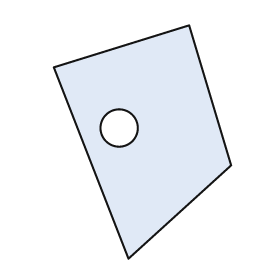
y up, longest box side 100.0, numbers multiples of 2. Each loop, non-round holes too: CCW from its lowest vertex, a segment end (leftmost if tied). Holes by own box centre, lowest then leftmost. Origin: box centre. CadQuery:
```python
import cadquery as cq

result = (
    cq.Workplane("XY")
    .moveTo(-6.0, -50.0)
    .lineTo(38.0, -10.0)
    .lineTo(20.0, 50.0)
    .lineTo(-38.0, 32.0)
    .close()
    .moveTo(-10.0, 6.0)
    .circle(8.0)
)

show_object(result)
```